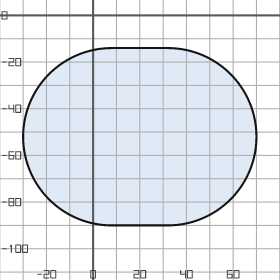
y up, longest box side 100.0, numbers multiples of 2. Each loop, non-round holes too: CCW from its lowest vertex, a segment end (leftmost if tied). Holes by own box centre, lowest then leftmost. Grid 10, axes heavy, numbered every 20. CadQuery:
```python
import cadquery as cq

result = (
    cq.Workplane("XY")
    .moveTo(8.0, -90.0)
    .lineTo(32.0, -90.0)
    .threePointArc((70.0, -52.0), (32.0, -14.0))
    .lineTo(8.0, -14.0)
    .threePointArc((-30.0, -52.0), (8.0, -90.0))
    .close()
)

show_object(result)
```